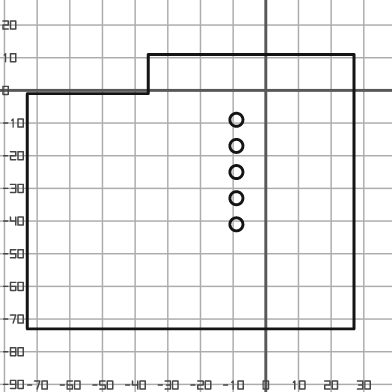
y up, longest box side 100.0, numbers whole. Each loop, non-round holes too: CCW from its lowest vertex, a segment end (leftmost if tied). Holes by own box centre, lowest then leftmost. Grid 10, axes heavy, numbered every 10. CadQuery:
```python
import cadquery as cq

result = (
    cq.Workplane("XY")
    .moveTo(-73.0, -73.0)
    .lineTo(27.0, -73.0)
    .lineTo(27.0, 11.0)
    .lineTo(-36.0, 11.0)
    .lineTo(-36.0, -1.0)
    .lineTo(-73.0, -1.0)
    .close()
    .moveTo(-9.0, -41.0)
    .circle(2.0)
    .moveTo(-9.0, -33.0)
    .circle(2.0)
    .moveTo(-9.0, -25.0)
    .circle(2.0)
    .moveTo(-9.0, -17.0)
    .circle(2.0)
    .moveTo(-9.0, -9.0)
    .circle(2.0)
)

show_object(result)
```